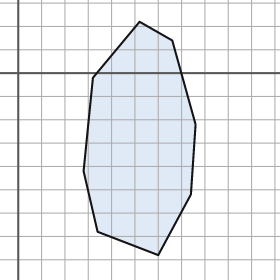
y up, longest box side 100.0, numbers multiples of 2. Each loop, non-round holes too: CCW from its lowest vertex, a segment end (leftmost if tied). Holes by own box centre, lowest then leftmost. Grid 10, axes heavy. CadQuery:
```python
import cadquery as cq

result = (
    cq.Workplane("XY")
    .moveTo(60.0, -78.0)
    .lineTo(74.0, -52.0)
    .lineTo(76.0, -22.0)
    .lineTo(66.0, 14.0)
    .lineTo(52.0, 22.0)
    .lineTo(32.0, -2.0)
    .lineTo(28.0, -42.0)
    .lineTo(34.0, -68.0)
    .close()
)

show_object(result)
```